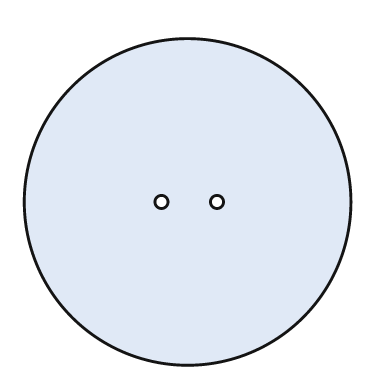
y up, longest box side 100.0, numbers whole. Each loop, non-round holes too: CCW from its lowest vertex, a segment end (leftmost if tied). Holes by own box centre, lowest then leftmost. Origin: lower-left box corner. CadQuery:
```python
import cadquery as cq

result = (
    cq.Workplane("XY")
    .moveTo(50.0, 50.0)
    .circle(50.0)
    .moveTo(42.0, 50.0)
    .circle(2.0)
    .moveTo(59.0, 50.0)
    .circle(2.0)
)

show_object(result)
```